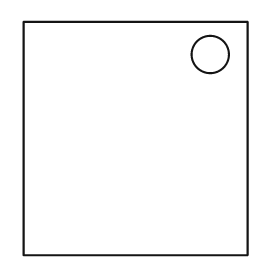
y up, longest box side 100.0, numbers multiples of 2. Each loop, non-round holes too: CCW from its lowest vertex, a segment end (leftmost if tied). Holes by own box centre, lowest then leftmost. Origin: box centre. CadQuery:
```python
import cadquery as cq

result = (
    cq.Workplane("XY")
    .moveTo(-48.0, -50.0)
    .lineTo(48.0, -50.0)
    .lineTo(48.0, 50.0)
    .lineTo(-48.0, 50.0)
    .close()
    .moveTo(32.0, 36.0)
    .circle(8.0)
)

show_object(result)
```